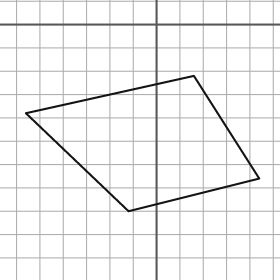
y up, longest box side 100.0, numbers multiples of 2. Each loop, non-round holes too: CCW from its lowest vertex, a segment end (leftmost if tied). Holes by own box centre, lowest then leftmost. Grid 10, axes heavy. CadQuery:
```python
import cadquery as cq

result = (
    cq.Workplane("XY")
    .moveTo(-12.0, -80.0)
    .lineTo(44.0, -66.0)
    .lineTo(16.0, -22.0)
    .lineTo(-56.0, -38.0)
    .close()
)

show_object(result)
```